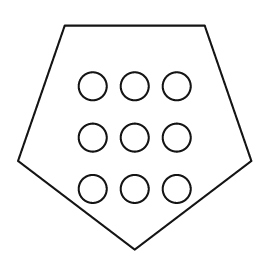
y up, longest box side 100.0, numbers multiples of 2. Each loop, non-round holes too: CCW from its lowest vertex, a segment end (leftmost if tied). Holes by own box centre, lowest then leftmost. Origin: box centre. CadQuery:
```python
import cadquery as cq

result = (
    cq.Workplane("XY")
    .moveTo(0.0, -48.0)
    .lineTo(50.0, -10.0)
    .lineTo(30.0, 48.0)
    .lineTo(-30.0, 48.0)
    .lineTo(-50.0, -10.0)
    .close()
    .moveTo(-18.0, -22.0)
    .circle(6.0)
    .moveTo(0.0, -22.0)
    .circle(6.0)
    .moveTo(18.0, -22.0)
    .circle(6.0)
    .moveTo(-18.0, 0.0)
    .circle(6.0)
    .moveTo(0.0, 0.0)
    .circle(6.0)
    .moveTo(18.0, 0.0)
    .circle(6.0)
    .moveTo(-18.0, 22.0)
    .circle(6.0)
    .moveTo(0.0, 22.0)
    .circle(6.0)
    .moveTo(18.0, 22.0)
    .circle(6.0)
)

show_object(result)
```